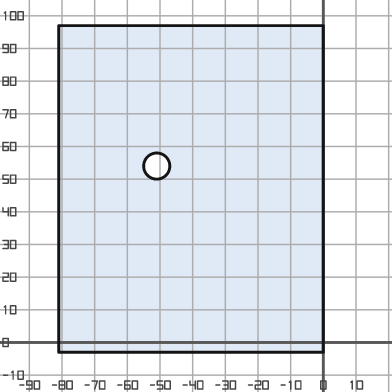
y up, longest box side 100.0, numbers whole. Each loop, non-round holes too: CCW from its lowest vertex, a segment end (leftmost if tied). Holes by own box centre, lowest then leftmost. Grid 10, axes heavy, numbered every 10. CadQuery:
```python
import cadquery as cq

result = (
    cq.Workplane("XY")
    .moveTo(-81.0, -3.0)
    .lineTo(0.0, -3.0)
    .lineTo(0.0, 97.0)
    .lineTo(-81.0, 97.0)
    .close()
    .moveTo(-51.0, 54.0)
    .circle(4.0)
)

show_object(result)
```